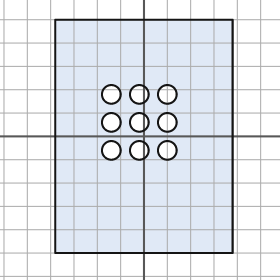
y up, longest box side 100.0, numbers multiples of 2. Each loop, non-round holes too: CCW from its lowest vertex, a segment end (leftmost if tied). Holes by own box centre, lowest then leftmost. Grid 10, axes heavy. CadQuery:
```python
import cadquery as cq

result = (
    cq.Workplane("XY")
    .moveTo(-38.0, -50.0)
    .lineTo(38.0, -50.0)
    .lineTo(38.0, 50.0)
    .lineTo(-38.0, 50.0)
    .close()
    .moveTo(-14.0, -6.0)
    .circle(4.0)
    .moveTo(-2.0, -6.0)
    .circle(4.0)
    .moveTo(10.0, -6.0)
    .circle(4.0)
    .moveTo(-14.0, 6.0)
    .circle(4.0)
    .moveTo(-2.0, 6.0)
    .circle(4.0)
    .moveTo(10.0, 6.0)
    .circle(4.0)
    .moveTo(-14.0, 18.0)
    .circle(4.0)
    .moveTo(-2.0, 18.0)
    .circle(4.0)
    .moveTo(10.0, 18.0)
    .circle(4.0)
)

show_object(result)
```